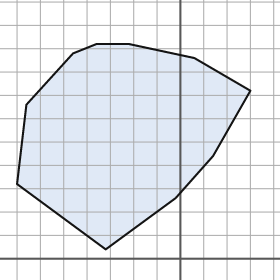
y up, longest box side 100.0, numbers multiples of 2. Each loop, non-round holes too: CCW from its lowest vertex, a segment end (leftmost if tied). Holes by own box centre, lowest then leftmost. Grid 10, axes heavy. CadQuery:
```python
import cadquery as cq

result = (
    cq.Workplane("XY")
    .moveTo(-32.0, 4.0)
    .lineTo(-2.0, 26.0)
    .lineTo(14.0, 44.0)
    .lineTo(30.0, 72.0)
    .lineTo(6.0, 86.0)
    .lineTo(-22.0, 92.0)
    .lineTo(-36.0, 92.0)
    .lineTo(-46.0, 88.0)
    .lineTo(-66.0, 66.0)
    .lineTo(-70.0, 32.0)
    .close()
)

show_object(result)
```